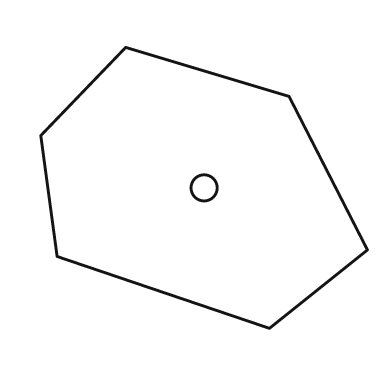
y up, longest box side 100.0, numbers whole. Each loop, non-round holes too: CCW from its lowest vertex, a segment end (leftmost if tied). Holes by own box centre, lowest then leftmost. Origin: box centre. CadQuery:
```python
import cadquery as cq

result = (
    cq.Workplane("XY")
    .moveTo(20.0, -43.0)
    .lineTo(50.0, -19.0)
    .lineTo(26.0, 28.0)
    .lineTo(-24.0, 43.0)
    .lineTo(-50.0, 16.0)
    .lineTo(-45.0, -21.0)
    .close()
    .moveTo(0.0, 0.0)
    .circle(4.0)
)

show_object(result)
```